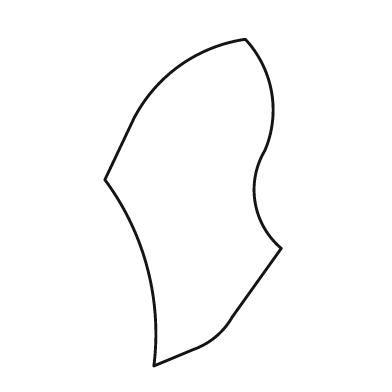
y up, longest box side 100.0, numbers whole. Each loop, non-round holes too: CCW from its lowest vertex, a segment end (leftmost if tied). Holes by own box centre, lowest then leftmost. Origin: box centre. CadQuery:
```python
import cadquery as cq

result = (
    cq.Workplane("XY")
    .moveTo(-12.0, -50.0)
    .lineTo(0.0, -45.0)
    .threePointArc((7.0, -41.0), (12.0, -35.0))
    .lineTo(27.0, -14.0)
    .threePointArc((19.0, 0.0), (22.0, 16.0))
    .threePointArc((24.0, 34.0), (16.0, 50.0))
    .threePointArc((-4.0, 42.0), (-18.0, 26.0))
    .lineTo(-27.0, 7.0)
    .threePointArc((-14.0, -20.0), (-12.0, -50.0))
    .close()
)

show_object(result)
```